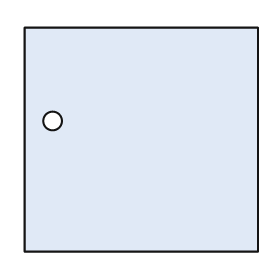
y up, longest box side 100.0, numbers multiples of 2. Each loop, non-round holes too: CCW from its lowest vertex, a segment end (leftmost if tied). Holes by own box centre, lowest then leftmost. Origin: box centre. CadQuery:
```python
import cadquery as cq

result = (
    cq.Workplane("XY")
    .moveTo(-50.0, -48.0)
    .lineTo(50.0, -48.0)
    .lineTo(50.0, 48.0)
    .lineTo(-50.0, 48.0)
    .close()
    .moveTo(-38.0, 8.0)
    .circle(4.0)
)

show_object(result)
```